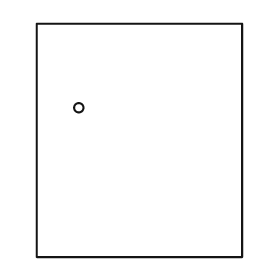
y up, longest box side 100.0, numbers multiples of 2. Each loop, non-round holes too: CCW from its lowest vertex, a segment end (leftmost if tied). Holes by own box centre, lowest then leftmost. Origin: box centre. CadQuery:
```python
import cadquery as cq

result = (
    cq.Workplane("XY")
    .moveTo(-44.0, -50.0)
    .lineTo(44.0, -50.0)
    .lineTo(44.0, 50.0)
    .lineTo(-44.0, 50.0)
    .close()
    .moveTo(-26.0, 14.0)
    .circle(2.0)
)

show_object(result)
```